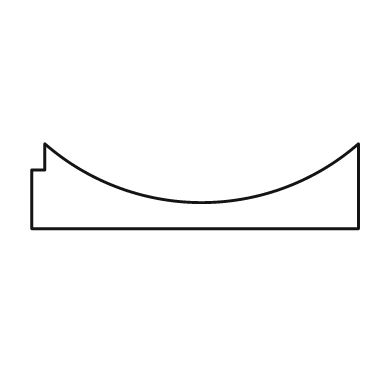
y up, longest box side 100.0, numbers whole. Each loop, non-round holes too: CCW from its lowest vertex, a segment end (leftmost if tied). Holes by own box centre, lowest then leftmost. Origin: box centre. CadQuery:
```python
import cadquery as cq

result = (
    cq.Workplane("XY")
    .moveTo(-50.0, -13.0)
    .lineTo(50.0, -13.0)
    .lineTo(50.0, 13.0)
    .threePointArc((2.0, -5.0), (-46.0, 13.0))
    .lineTo(-46.0, 5.0)
    .lineTo(-50.0, 5.0)
    .close()
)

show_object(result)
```